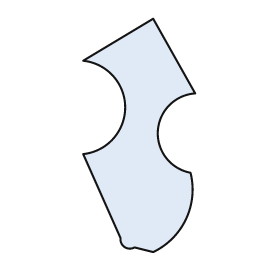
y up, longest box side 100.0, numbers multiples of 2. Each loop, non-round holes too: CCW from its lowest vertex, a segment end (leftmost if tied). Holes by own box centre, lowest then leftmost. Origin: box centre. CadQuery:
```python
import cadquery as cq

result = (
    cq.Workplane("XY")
    .moveTo(6.0, -50.0)
    .threePointArc((20.0, -36.0), (22.0, -16.0))
    .threePointArc((8.0, 2.0), (24.0, 18.0))
    .lineTo(6.0, 50.0)
    .lineTo(-24.0, 32.0)
    .threePointArc((-6.0, 12.0), (-24.0, -8.0))
    .lineTo(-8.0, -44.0)
    .threePointArc((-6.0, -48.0), (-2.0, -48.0))
    .close()
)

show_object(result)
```